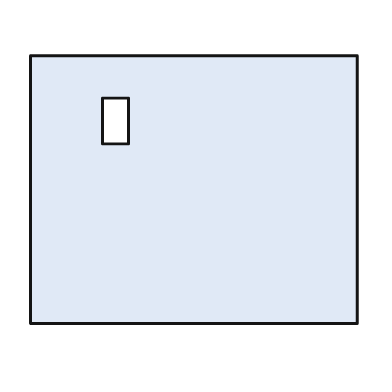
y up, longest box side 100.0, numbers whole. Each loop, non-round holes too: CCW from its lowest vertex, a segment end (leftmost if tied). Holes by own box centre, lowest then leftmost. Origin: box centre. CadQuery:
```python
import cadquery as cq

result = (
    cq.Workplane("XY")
    .moveTo(-50.0, -41.0)
    .lineTo(50.0, -41.0)
    .lineTo(50.0, 41.0)
    .lineTo(-50.0, 41.0)
    .close()
    .moveTo(-28.0, 14.0)
    .lineTo(-20.0, 14.0)
    .lineTo(-20.0, 28.0)
    .lineTo(-28.0, 28.0)
    .close()
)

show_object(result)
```